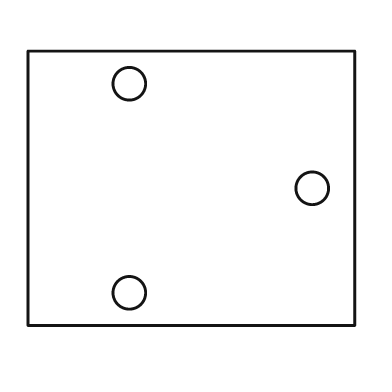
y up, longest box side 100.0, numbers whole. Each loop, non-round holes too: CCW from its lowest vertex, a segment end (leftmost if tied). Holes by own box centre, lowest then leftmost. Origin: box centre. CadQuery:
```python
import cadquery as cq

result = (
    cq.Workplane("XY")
    .moveTo(-50.0, -42.0)
    .lineTo(50.0, -42.0)
    .lineTo(50.0, 42.0)
    .lineTo(-50.0, 42.0)
    .close()
    .moveTo(-19.0, -32.0)
    .circle(5.0)
    .moveTo(37.0, 0.0)
    .circle(5.0)
    .moveTo(-19.0, 32.0)
    .circle(5.0)
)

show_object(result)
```